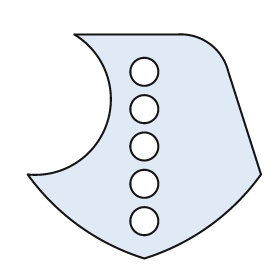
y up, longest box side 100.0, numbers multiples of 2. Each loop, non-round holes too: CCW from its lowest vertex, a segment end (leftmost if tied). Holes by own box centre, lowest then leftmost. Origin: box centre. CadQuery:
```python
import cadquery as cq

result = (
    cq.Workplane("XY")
    .moveTo(0.0, -48.0)
    .threePointArc((28.0, -34.0), (50.0, -12.0))
    .lineTo(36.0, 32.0)
    .threePointArc((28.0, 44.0), (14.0, 48.0))
    .lineTo(-30.0, 48.0)
    .threePointArc((-16.0, 10.0), (-50.0, -12.0))
    .threePointArc((-28.0, -34.0), (0.0, -48.0))
    .close()
    .moveTo(0.0, -32.0)
    .circle(6.0)
    .moveTo(0.0, -16.0)
    .circle(6.0)
    .moveTo(0.0, 0.0)
    .circle(6.0)
    .moveTo(0.0, 16.0)
    .circle(6.0)
    .moveTo(0.0, 32.0)
    .circle(6.0)
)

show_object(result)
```